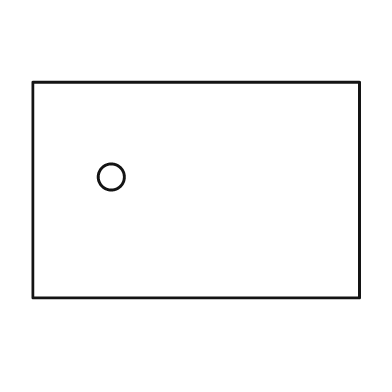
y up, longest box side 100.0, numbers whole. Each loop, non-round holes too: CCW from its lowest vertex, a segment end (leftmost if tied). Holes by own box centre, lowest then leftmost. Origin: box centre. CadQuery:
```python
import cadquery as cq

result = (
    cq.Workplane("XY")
    .moveTo(-50.0, -33.0)
    .lineTo(50.0, -33.0)
    .lineTo(50.0, 33.0)
    .lineTo(-50.0, 33.0)
    .close()
    .moveTo(-26.0, 4.0)
    .circle(4.0)
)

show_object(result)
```